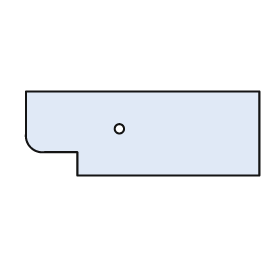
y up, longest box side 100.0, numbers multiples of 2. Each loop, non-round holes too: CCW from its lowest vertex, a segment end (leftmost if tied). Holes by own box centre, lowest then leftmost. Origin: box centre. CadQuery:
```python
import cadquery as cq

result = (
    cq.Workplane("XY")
    .moveTo(-28.0, -18.0)
    .lineTo(50.0, -18.0)
    .lineTo(50.0, 18.0)
    .lineTo(-50.0, 18.0)
    .lineTo(-50.0, 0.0)
    .threePointArc((-48.0, -6.0), (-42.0, -8.0))
    .lineTo(-28.0, -8.0)
    .close()
    .moveTo(-10.0, 2.0)
    .circle(2.0)
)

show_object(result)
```